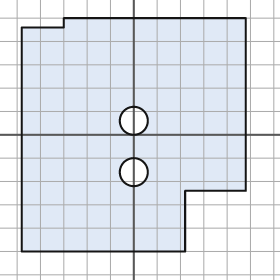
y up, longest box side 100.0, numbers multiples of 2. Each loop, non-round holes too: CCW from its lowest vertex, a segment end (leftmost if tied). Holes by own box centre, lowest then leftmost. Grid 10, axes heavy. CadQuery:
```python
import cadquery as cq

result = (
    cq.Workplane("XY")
    .moveTo(-48.0, -50.0)
    .lineTo(22.0, -50.0)
    .lineTo(22.0, -24.0)
    .lineTo(48.0, -24.0)
    .lineTo(48.0, 50.0)
    .lineTo(-30.0, 50.0)
    .lineTo(-30.0, 46.0)
    .lineTo(-48.0, 46.0)
    .close()
    .moveTo(0.0, -16.0)
    .circle(6.0)
    .moveTo(0.0, 6.0)
    .circle(6.0)
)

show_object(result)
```